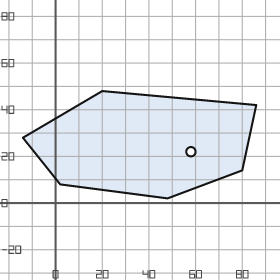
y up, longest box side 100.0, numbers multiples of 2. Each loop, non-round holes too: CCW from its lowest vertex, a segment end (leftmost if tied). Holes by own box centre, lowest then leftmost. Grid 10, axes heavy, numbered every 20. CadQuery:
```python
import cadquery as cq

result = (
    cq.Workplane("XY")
    .moveTo(48.0, 2.0)
    .lineTo(80.0, 14.0)
    .lineTo(86.0, 42.0)
    .lineTo(20.0, 48.0)
    .lineTo(-14.0, 28.0)
    .lineTo(2.0, 8.0)
    .close()
    .moveTo(58.0, 22.0)
    .circle(2.0)
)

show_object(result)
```